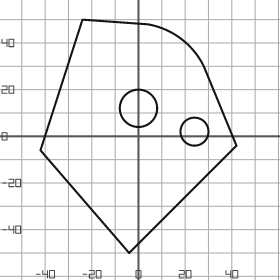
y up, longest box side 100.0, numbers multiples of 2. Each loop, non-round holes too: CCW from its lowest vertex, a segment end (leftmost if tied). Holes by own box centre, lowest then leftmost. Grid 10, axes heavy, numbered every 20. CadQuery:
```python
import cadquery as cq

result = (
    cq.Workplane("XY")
    .moveTo(-4.0, -50.0)
    .lineTo(42.0, -4.0)
    .lineTo(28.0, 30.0)
    .threePointArc((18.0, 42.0), (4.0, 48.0))
    .lineTo(-24.0, 50.0)
    .lineTo(-42.0, -6.0)
    .close()
    .moveTo(24.0, 2.0)
    .circle(6.0)
    .moveTo(0.0, 12.0)
    .circle(8.0)
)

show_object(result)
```